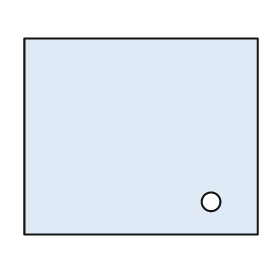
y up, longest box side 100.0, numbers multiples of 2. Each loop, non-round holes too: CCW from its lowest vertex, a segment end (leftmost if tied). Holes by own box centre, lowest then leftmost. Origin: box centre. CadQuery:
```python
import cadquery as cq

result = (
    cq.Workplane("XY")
    .moveTo(-50.0, -42.0)
    .lineTo(50.0, -42.0)
    .lineTo(50.0, 42.0)
    .lineTo(-50.0, 42.0)
    .close()
    .moveTo(30.0, -28.0)
    .circle(4.0)
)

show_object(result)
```